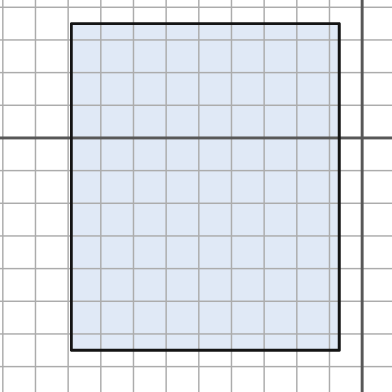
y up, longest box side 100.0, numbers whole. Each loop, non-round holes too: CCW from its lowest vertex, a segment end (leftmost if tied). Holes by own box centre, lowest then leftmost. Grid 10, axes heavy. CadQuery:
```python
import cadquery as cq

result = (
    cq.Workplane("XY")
    .moveTo(-89.0, -65.0)
    .lineTo(-7.0, -65.0)
    .lineTo(-7.0, 35.0)
    .lineTo(-89.0, 35.0)
    .close()
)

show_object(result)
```